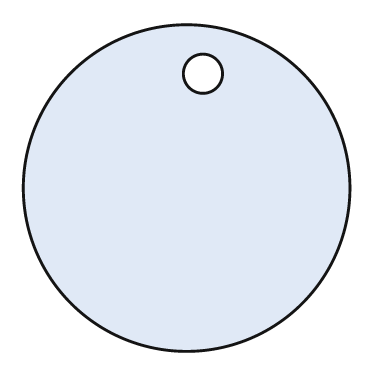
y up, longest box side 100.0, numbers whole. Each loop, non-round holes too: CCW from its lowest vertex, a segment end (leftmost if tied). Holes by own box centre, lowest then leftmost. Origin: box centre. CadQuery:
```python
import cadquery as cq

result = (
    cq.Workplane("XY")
    .moveTo(0.0, 0.0)
    .circle(50.0)
    .moveTo(5.0, 35.0)
    .circle(6.0)
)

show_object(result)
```